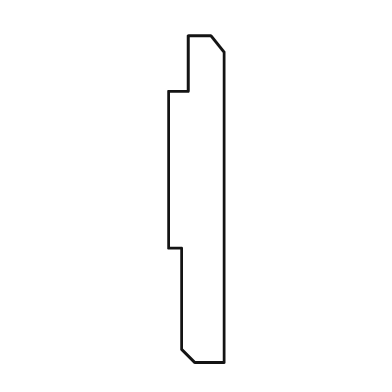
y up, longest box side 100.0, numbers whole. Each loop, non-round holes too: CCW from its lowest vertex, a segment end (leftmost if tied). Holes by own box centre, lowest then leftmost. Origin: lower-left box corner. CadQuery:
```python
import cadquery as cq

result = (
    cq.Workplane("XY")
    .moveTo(8.0, 0.0)
    .lineTo(17.0, 0.0)
    .lineTo(17.0, 95.0)
    .lineTo(13.0, 100.0)
    .lineTo(6.0, 100.0)
    .lineTo(6.0, 83.0)
    .lineTo(0.0, 83.0)
    .lineTo(0.0, 35.0)
    .lineTo(4.0, 35.0)
    .lineTo(4.0, 4.0)
    .close()
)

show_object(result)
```